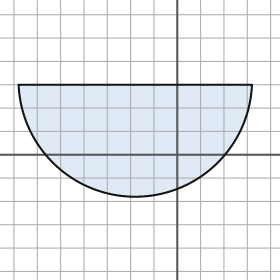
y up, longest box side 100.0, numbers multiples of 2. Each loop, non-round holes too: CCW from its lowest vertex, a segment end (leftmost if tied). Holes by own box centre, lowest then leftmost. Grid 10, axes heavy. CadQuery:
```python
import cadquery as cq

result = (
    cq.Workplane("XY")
    .moveTo(-68.0, 30.0)
    .threePointArc((-18.0, -18.0), (32.0, 30.0))
    .close()
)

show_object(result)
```